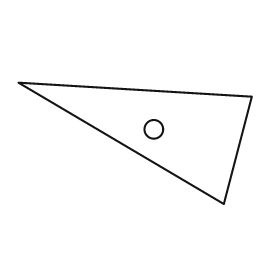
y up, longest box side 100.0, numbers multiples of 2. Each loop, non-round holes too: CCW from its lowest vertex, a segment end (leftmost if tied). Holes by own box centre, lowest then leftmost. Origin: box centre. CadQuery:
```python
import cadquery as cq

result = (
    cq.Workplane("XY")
    .moveTo(38.0, -26.0)
    .lineTo(50.0, 20.0)
    .lineTo(-50.0, 26.0)
    .close()
    .moveTo(8.0, 6.0)
    .circle(4.0)
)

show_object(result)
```